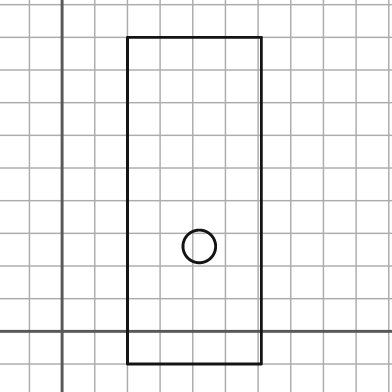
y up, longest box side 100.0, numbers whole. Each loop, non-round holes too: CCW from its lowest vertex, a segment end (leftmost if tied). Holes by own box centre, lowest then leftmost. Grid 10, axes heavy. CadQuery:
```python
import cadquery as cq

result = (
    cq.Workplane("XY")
    .moveTo(20.0, -10.0)
    .lineTo(61.0, -10.0)
    .lineTo(61.0, 90.0)
    .lineTo(20.0, 90.0)
    .close()
    .moveTo(42.0, 26.0)
    .circle(5.0)
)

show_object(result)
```